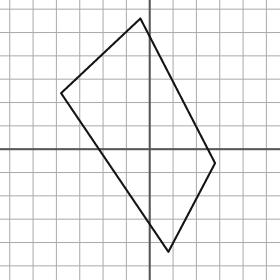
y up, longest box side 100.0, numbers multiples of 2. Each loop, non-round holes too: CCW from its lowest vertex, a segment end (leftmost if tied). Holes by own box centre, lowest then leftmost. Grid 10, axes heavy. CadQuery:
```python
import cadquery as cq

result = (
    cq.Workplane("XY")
    .moveTo(8.0, -44.0)
    .lineTo(28.0, -6.0)
    .lineTo(-4.0, 56.0)
    .lineTo(-38.0, 24.0)
    .close()
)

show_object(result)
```